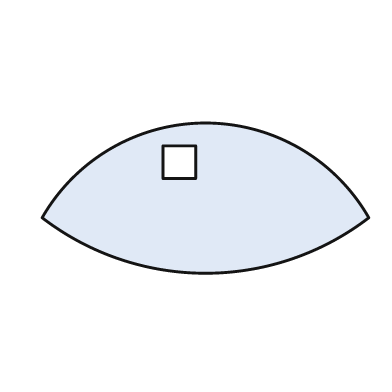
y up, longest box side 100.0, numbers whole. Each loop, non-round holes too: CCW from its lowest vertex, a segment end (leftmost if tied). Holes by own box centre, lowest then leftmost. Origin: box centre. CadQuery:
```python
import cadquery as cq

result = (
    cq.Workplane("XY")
    .moveTo(-50.0, -6.0)
    .threePointArc((0.0, -23.0), (50.0, -6.0))
    .threePointArc((0.0, 23.0), (-50.0, -6.0))
    .close()
    .moveTo(-13.0, 6.0)
    .lineTo(-3.0, 6.0)
    .lineTo(-3.0, 16.0)
    .lineTo(-13.0, 16.0)
    .close()
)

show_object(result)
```